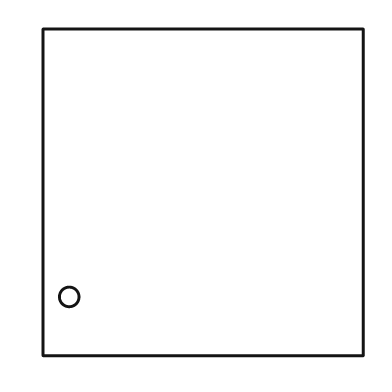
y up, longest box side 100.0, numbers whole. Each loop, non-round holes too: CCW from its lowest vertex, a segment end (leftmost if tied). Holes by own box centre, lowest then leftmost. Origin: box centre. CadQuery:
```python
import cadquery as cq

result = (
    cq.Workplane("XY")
    .moveTo(-49.0, -50.0)
    .lineTo(49.0, -50.0)
    .lineTo(49.0, 50.0)
    .lineTo(-49.0, 50.0)
    .close()
    .moveTo(-41.0, -32.0)
    .circle(3.0)
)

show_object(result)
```